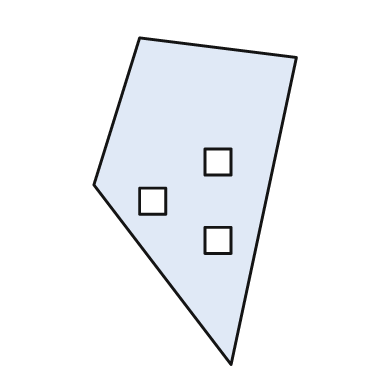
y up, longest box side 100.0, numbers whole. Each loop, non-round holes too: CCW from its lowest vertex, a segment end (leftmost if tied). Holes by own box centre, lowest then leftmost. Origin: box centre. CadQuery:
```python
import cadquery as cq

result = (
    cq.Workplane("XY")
    .moveTo(11.0, -50.0)
    .lineTo(31.0, 44.0)
    .lineTo(-17.0, 50.0)
    .lineTo(-31.0, 5.0)
    .close()
    .moveTo(3.0, -16.0)
    .lineTo(11.0, -16.0)
    .lineTo(11.0, -8.0)
    .lineTo(3.0, -8.0)
    .close()
    .moveTo(-17.0, -4.0)
    .lineTo(-9.0, -4.0)
    .lineTo(-9.0, 4.0)
    .lineTo(-17.0, 4.0)
    .close()
    .moveTo(3.0, 8.0)
    .lineTo(11.0, 8.0)
    .lineTo(11.0, 16.0)
    .lineTo(3.0, 16.0)
    .close()
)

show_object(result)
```